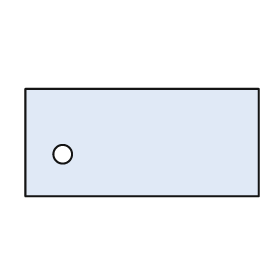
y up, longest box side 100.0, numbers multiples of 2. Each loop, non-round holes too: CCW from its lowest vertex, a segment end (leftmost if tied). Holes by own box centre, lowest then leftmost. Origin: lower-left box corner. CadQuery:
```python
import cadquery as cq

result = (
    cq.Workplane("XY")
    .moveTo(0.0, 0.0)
    .lineTo(100.0, 0.0)
    .lineTo(100.0, 46.0)
    .lineTo(0.0, 46.0)
    .close()
    .moveTo(16.0, 18.0)
    .circle(4.0)
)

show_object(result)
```